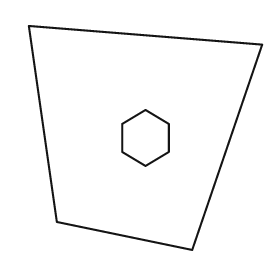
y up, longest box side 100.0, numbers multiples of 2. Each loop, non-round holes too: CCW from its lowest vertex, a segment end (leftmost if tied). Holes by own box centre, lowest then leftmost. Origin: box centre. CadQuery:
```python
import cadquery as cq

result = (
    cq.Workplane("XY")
    .moveTo(20.0, -48.0)
    .lineTo(50.0, 40.0)
    .lineTo(-50.0, 48.0)
    .lineTo(-38.0, -36.0)
    .close()
    .moveTo(0.0, -12.0)
    .lineTo(10.0, -6.0)
    .lineTo(10.0, 6.0)
    .lineTo(0.0, 12.0)
    .lineTo(-10.0, 6.0)
    .lineTo(-10.0, -6.0)
    .close()
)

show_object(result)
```